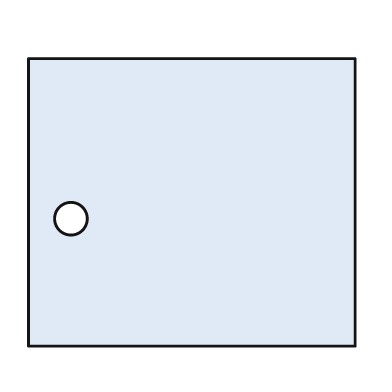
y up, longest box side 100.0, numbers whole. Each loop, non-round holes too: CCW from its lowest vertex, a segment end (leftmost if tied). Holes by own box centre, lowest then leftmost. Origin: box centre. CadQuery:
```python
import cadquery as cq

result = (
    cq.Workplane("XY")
    .moveTo(-50.0, -44.0)
    .lineTo(50.0, -44.0)
    .lineTo(50.0, 44.0)
    .lineTo(-50.0, 44.0)
    .close()
    .moveTo(-37.0, -5.0)
    .circle(5.0)
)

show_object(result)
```